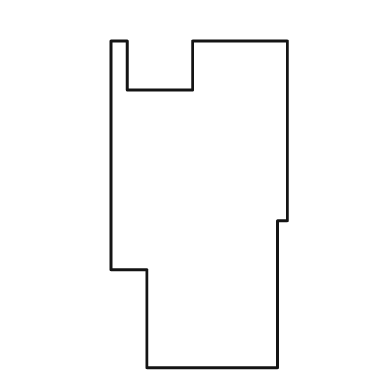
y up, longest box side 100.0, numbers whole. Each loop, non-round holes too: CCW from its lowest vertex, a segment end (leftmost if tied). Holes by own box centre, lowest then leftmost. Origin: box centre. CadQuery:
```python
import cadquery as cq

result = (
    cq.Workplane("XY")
    .moveTo(-16.0, -50.0)
    .lineTo(24.0, -50.0)
    .lineTo(24.0, -5.0)
    .lineTo(27.0, -5.0)
    .lineTo(27.0, 50.0)
    .lineTo(-2.0, 50.0)
    .lineTo(-2.0, 35.0)
    .lineTo(-22.0, 35.0)
    .lineTo(-22.0, 50.0)
    .lineTo(-27.0, 50.0)
    .lineTo(-27.0, -20.0)
    .lineTo(-16.0, -20.0)
    .close()
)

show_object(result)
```